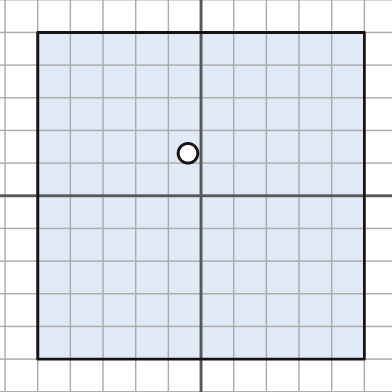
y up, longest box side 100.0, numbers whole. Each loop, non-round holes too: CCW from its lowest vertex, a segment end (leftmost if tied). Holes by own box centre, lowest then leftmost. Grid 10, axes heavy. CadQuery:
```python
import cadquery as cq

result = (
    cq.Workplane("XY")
    .moveTo(-50.0, -50.0)
    .lineTo(50.0, -50.0)
    .lineTo(50.0, 50.0)
    .lineTo(-50.0, 50.0)
    .close()
    .moveTo(-4.0, 13.0)
    .circle(3.0)
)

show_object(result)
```